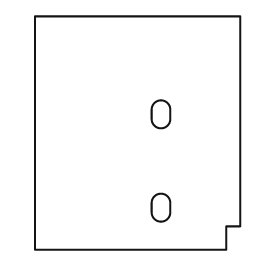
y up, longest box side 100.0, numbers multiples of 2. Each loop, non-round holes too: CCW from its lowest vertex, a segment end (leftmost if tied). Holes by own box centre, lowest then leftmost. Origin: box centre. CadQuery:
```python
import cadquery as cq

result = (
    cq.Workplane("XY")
    .moveTo(-44.0, -50.0)
    .lineTo(38.0, -50.0)
    .lineTo(38.0, -40.0)
    .lineTo(44.0, -40.0)
    .lineTo(44.0, 50.0)
    .lineTo(-44.0, 50.0)
    .close()
    .moveTo(6.0, -34.0)
    .threePointArc((10.0, -38.0), (14.0, -34.0))
    .lineTo(14.0, -30.0)
    .threePointArc((10.0, -26.0), (6.0, -30.0))
    .close()
    .moveTo(6.0, 6.0)
    .threePointArc((10.0, 2.0), (14.0, 6.0))
    .lineTo(14.0, 10.0)
    .threePointArc((10.0, 14.0), (6.0, 10.0))
    .close()
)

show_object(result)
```